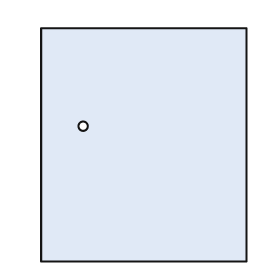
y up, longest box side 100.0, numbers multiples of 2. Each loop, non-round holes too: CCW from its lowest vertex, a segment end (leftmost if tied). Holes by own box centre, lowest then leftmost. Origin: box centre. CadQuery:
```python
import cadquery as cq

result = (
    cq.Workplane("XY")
    .moveTo(-44.0, -50.0)
    .lineTo(44.0, -50.0)
    .lineTo(44.0, 50.0)
    .lineTo(-44.0, 50.0)
    .close()
    .moveTo(-26.0, 8.0)
    .circle(2.0)
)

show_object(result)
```